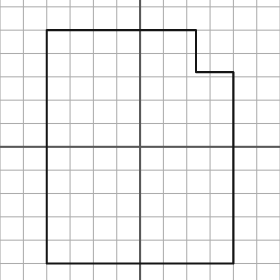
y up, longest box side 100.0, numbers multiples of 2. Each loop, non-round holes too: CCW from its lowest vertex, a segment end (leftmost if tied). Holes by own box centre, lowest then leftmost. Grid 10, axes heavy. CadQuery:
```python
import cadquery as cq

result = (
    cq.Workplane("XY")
    .moveTo(-40.0, -50.0)
    .lineTo(40.0, -50.0)
    .lineTo(40.0, 32.0)
    .lineTo(24.0, 32.0)
    .lineTo(24.0, 50.0)
    .lineTo(-40.0, 50.0)
    .close()
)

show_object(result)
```